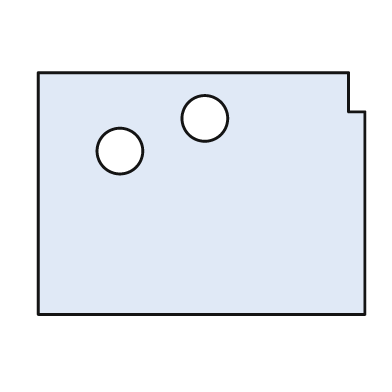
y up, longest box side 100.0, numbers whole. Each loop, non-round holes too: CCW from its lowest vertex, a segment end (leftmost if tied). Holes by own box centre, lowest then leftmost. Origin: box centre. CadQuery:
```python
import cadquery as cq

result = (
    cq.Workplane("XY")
    .moveTo(-50.0, -37.0)
    .lineTo(50.0, -37.0)
    .lineTo(50.0, 25.0)
    .lineTo(45.0, 25.0)
    .lineTo(45.0, 37.0)
    .lineTo(-50.0, 37.0)
    .close()
    .moveTo(-25.0, 13.0)
    .circle(7.0)
    .moveTo(1.0, 23.0)
    .circle(7.0)
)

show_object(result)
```